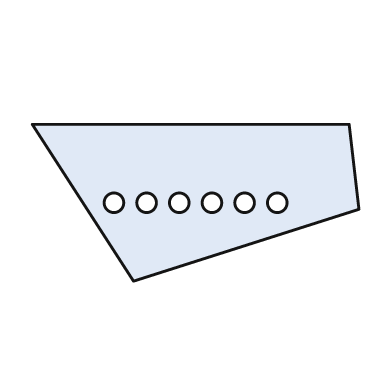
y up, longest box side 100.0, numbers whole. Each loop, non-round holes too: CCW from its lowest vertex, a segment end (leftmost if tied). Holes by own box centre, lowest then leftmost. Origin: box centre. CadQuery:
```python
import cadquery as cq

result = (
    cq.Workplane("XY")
    .moveTo(-19.0, -24.0)
    .lineTo(50.0, -2.0)
    .lineTo(47.0, 24.0)
    .lineTo(-50.0, 24.0)
    .close()
    .moveTo(-25.0, 0.0)
    .circle(3.0)
    .moveTo(-15.0, 0.0)
    .circle(3.0)
    .moveTo(-5.0, 0.0)
    .circle(3.0)
    .moveTo(5.0, 0.0)
    .circle(3.0)
    .moveTo(15.0, 0.0)
    .circle(3.0)
    .moveTo(25.0, 0.0)
    .circle(3.0)
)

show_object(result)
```